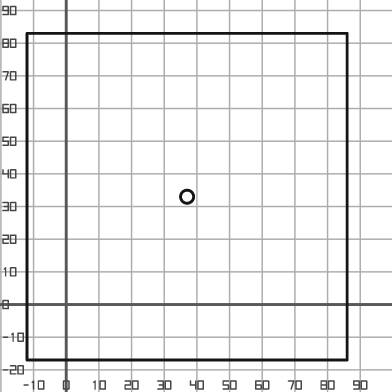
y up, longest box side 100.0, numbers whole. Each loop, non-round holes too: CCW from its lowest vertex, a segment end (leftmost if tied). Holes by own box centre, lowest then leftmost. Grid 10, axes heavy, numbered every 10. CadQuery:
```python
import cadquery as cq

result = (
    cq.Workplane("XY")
    .moveTo(-12.0, -17.0)
    .lineTo(86.0, -17.0)
    .lineTo(86.0, 83.0)
    .lineTo(-12.0, 83.0)
    .close()
    .moveTo(37.0, 33.0)
    .circle(2.0)
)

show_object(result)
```